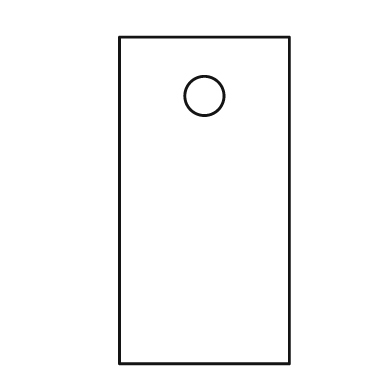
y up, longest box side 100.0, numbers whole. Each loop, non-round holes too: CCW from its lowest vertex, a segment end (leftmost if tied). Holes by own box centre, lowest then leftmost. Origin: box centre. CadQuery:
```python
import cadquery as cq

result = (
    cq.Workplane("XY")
    .moveTo(-26.0, -50.0)
    .lineTo(26.0, -50.0)
    .lineTo(26.0, 50.0)
    .lineTo(-26.0, 50.0)
    .close()
    .moveTo(0.0, 32.0)
    .circle(6.0)
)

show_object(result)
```